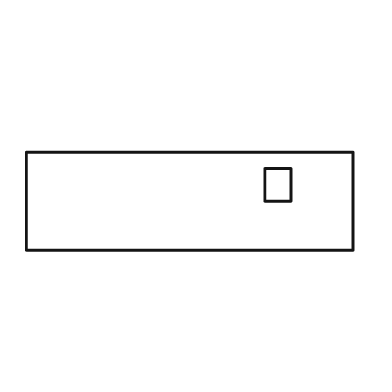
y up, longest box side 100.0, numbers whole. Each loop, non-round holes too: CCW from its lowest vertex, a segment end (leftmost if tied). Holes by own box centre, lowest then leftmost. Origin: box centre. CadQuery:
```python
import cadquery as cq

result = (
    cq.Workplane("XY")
    .moveTo(-50.0, -15.0)
    .lineTo(50.0, -15.0)
    .lineTo(50.0, 15.0)
    .lineTo(-50.0, 15.0)
    .close()
    .moveTo(23.0, 0.0)
    .lineTo(31.0, 0.0)
    .lineTo(31.0, 10.0)
    .lineTo(23.0, 10.0)
    .close()
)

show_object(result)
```